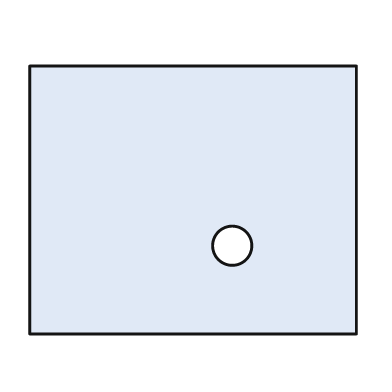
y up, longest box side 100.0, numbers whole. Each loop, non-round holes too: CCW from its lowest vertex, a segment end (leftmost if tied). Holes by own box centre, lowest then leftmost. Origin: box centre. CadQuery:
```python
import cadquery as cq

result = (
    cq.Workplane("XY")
    .moveTo(-50.0, -41.0)
    .lineTo(50.0, -41.0)
    .lineTo(50.0, 41.0)
    .lineTo(-50.0, 41.0)
    .close()
    .moveTo(12.0, -14.0)
    .circle(6.0)
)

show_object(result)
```